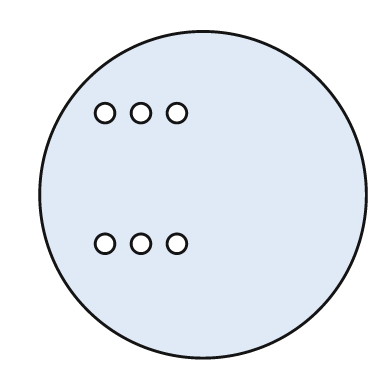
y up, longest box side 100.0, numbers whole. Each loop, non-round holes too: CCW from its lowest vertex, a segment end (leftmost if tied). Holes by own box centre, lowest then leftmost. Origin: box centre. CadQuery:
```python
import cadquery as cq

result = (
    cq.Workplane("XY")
    .moveTo(0.0, 0.0)
    .circle(50.0)
    .moveTo(-30.0, -15.0)
    .circle(3.0)
    .moveTo(-19.0, -15.0)
    .circle(3.0)
    .moveTo(-8.0, -15.0)
    .circle(3.0)
    .moveTo(-30.0, 25.0)
    .circle(3.0)
    .moveTo(-19.0, 25.0)
    .circle(3.0)
    .moveTo(-8.0, 25.0)
    .circle(3.0)
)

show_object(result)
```